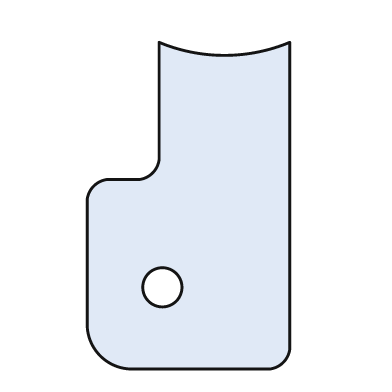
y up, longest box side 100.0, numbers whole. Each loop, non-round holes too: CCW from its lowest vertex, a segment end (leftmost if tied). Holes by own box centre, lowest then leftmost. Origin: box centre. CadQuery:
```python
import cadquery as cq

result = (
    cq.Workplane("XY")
    .moveTo(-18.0, -50.0)
    .lineTo(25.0, -50.0)
    .threePointArc((29.0, -48.0), (31.0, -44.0))
    .lineTo(31.0, 50.0)
    .threePointArc((11.0, 46.0), (-9.0, 50.0))
    .lineTo(-9.0, 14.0)
    .threePointArc((-11.0, 10.0), (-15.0, 8.0))
    .lineTo(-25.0, 8.0)
    .threePointArc((-29.0, 6.0), (-31.0, 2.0))
    .lineTo(-31.0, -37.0)
    .threePointArc((-27.0, -46.0), (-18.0, -50.0))
    .close()
    .moveTo(-8.0, -25.0)
    .circle(6.0)
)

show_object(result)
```